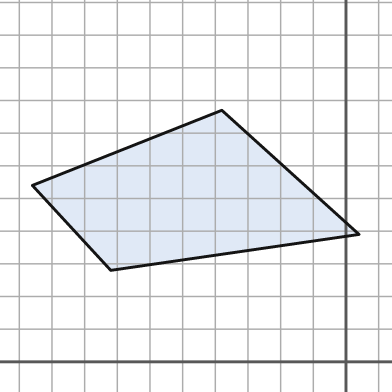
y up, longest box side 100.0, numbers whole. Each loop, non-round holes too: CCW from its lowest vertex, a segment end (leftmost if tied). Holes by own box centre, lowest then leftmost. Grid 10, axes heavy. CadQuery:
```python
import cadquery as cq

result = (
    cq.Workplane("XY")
    .moveTo(-72.0, 28.0)
    .lineTo(4.0, 39.0)
    .lineTo(-38.0, 77.0)
    .lineTo(-96.0, 54.0)
    .close()
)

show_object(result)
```